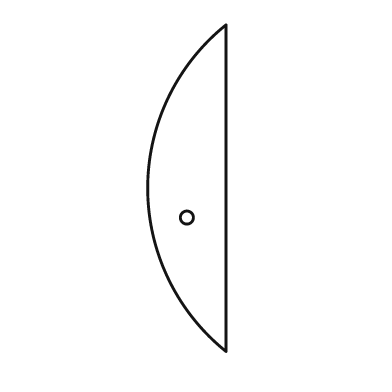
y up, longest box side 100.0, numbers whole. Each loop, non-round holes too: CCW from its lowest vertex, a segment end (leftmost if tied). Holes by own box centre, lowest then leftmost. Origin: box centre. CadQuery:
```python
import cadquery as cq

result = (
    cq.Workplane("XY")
    .moveTo(12.0, -50.0)
    .lineTo(12.0, 50.0)
    .threePointArc((-12.0, 0.0), (12.0, -50.0))
    .close()
    .moveTo(0.0, -9.0)
    .circle(2.0)
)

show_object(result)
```